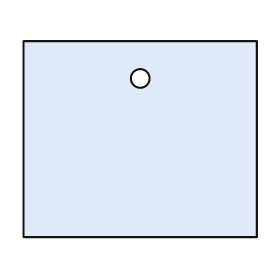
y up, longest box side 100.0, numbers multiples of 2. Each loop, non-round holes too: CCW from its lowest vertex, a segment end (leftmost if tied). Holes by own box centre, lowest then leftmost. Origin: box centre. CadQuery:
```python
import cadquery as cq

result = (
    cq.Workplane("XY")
    .moveTo(-50.0, -42.0)
    .lineTo(50.0, -42.0)
    .lineTo(50.0, 42.0)
    .lineTo(-50.0, 42.0)
    .close()
    .moveTo(0.0, 26.0)
    .circle(4.0)
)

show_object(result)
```